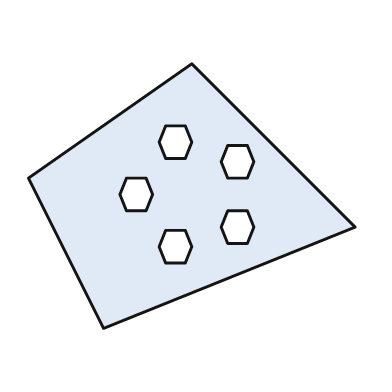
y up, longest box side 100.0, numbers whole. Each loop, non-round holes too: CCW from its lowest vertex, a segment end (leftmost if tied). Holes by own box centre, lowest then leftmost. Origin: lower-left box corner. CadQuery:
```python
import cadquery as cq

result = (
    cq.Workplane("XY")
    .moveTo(23.0, 0.0)
    .lineTo(100.0, 31.0)
    .lineTo(50.0, 81.0)
    .lineTo(0.0, 46.0)
    .close()
    .moveTo(42.0, 20.0)
    .lineTo(48.0, 20.0)
    .lineTo(50.0, 25.0)
    .lineTo(48.0, 30.0)
    .lineTo(42.0, 30.0)
    .lineTo(40.0, 25.0)
    .close()
    .moveTo(61.0, 26.0)
    .lineTo(67.0, 26.0)
    .lineTo(69.0, 31.0)
    .lineTo(67.0, 36.0)
    .lineTo(61.0, 36.0)
    .lineTo(59.0, 31.0)
    .close()
    .moveTo(30.0, 36.0)
    .lineTo(36.0, 36.0)
    .lineTo(38.0, 41.0)
    .lineTo(36.0, 46.0)
    .lineTo(30.0, 46.0)
    .lineTo(28.0, 41.0)
    .close()
    .moveTo(61.0, 46.0)
    .lineTo(67.0, 46.0)
    .lineTo(69.0, 51.0)
    .lineTo(67.0, 56.0)
    .lineTo(61.0, 56.0)
    .lineTo(59.0, 51.0)
    .close()
    .moveTo(42.0, 52.0)
    .lineTo(48.0, 52.0)
    .lineTo(50.0, 57.0)
    .lineTo(48.0, 62.0)
    .lineTo(42.0, 62.0)
    .lineTo(40.0, 57.0)
    .close()
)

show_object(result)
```